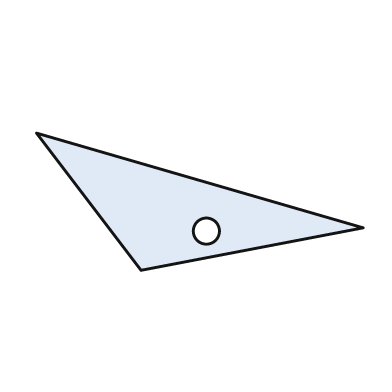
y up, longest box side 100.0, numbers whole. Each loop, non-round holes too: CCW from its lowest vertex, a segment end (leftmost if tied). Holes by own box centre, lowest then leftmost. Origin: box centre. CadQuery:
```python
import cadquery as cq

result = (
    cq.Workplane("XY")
    .moveTo(-18.0, -21.0)
    .lineTo(50.0, -8.0)
    .lineTo(-50.0, 21.0)
    .close()
    .moveTo(2.0, -9.0)
    .circle(4.0)
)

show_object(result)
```